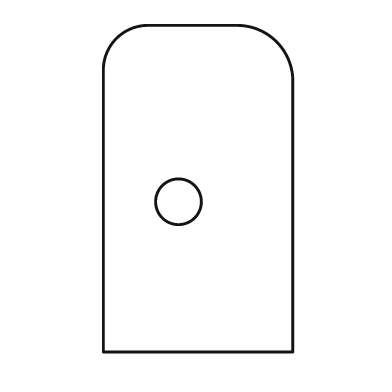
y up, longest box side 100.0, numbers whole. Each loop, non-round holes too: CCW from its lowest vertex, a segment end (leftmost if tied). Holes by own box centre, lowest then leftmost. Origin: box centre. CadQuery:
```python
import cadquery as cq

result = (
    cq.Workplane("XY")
    .moveTo(-29.0, -50.0)
    .lineTo(29.0, -50.0)
    .lineTo(29.0, 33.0)
    .threePointArc((24.0, 45.0), (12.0, 50.0))
    .lineTo(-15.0, 50.0)
    .threePointArc((-25.0, 46.0), (-29.0, 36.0))
    .close()
    .moveTo(-6.0, -4.0)
    .circle(7.0)
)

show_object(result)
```